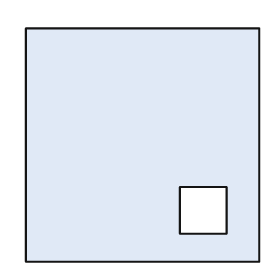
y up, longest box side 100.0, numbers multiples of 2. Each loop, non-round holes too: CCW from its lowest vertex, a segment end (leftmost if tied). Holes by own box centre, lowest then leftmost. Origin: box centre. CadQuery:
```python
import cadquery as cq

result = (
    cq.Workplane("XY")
    .moveTo(-50.0, -50.0)
    .lineTo(50.0, -50.0)
    .lineTo(50.0, 50.0)
    .lineTo(-50.0, 50.0)
    .close()
    .moveTo(16.0, -38.0)
    .lineTo(36.0, -38.0)
    .lineTo(36.0, -18.0)
    .lineTo(16.0, -18.0)
    .close()
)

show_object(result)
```